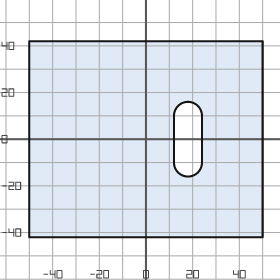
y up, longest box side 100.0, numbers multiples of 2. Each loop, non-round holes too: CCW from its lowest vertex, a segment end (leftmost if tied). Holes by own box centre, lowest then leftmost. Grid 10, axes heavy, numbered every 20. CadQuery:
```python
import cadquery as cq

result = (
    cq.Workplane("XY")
    .moveTo(-50.0, -42.0)
    .lineTo(50.0, -42.0)
    .lineTo(50.0, 42.0)
    .lineTo(-50.0, 42.0)
    .close()
    .moveTo(12.0, -10.0)
    .threePointArc((18.0, -16.0), (24.0, -10.0))
    .lineTo(24.0, 10.0)
    .threePointArc((18.0, 16.0), (12.0, 10.0))
    .close()
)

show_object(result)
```